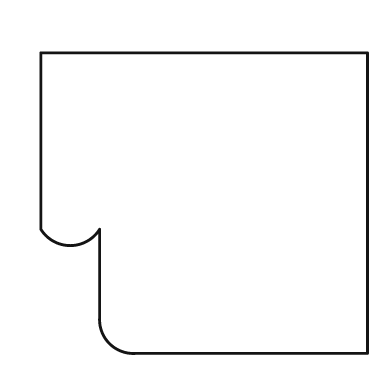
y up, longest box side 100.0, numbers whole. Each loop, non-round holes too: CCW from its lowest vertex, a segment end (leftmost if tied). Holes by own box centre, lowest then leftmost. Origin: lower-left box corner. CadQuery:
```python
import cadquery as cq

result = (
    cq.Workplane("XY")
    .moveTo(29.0, 0.0)
    .lineTo(100.0, 0.0)
    .lineTo(100.0, 92.0)
    .lineTo(0.0, 92.0)
    .lineTo(0.0, 38.0)
    .threePointArc((9.0, 33.0), (18.0, 38.0))
    .lineTo(18.0, 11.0)
    .threePointArc((21.0, 3.0), (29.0, 0.0))
    .close()
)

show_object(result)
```